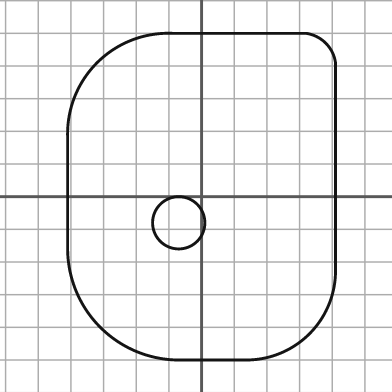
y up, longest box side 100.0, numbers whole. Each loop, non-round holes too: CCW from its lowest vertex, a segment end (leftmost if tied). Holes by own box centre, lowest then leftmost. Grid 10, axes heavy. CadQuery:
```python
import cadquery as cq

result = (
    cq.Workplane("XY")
    .moveTo(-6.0, -50.0)
    .lineTo(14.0, -50.0)
    .threePointArc((33.0, -42.0), (41.0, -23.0))
    .lineTo(41.0, 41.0)
    .threePointArc((38.0, 47.0), (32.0, 50.0))
    .lineTo(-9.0, 50.0)
    .threePointArc((-32.0, 41.0), (-41.0, 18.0))
    .lineTo(-41.0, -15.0)
    .threePointArc((-31.0, -40.0), (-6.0, -50.0))
    .close()
    .moveTo(-7.0, -8.0)
    .circle(8.0)
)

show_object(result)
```